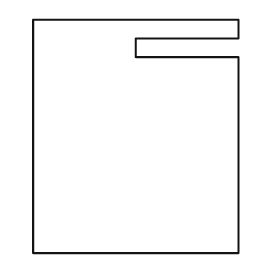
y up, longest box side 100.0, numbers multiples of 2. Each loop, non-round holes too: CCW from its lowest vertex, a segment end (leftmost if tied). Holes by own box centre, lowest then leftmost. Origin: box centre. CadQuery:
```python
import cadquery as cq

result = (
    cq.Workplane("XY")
    .moveTo(-44.0, -50.0)
    .lineTo(44.0, -50.0)
    .lineTo(44.0, 34.0)
    .lineTo(0.0, 34.0)
    .lineTo(0.0, 42.0)
    .lineTo(44.0, 42.0)
    .lineTo(44.0, 50.0)
    .lineTo(-44.0, 50.0)
    .close()
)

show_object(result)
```